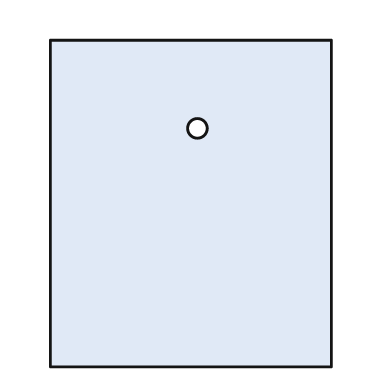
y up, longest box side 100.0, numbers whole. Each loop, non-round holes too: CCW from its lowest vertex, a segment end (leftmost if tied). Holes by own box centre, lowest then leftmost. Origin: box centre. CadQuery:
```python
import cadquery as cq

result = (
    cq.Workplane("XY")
    .moveTo(-43.0, -50.0)
    .lineTo(43.0, -50.0)
    .lineTo(43.0, 50.0)
    .lineTo(-43.0, 50.0)
    .close()
    .moveTo(2.0, 23.0)
    .circle(3.0)
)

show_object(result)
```